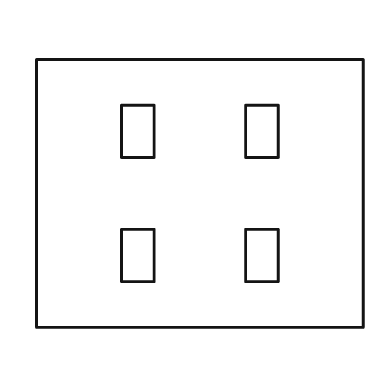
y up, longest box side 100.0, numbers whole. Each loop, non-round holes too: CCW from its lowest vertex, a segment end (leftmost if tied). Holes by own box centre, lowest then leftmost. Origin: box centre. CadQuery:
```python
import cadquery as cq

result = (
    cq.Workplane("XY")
    .moveTo(-50.0, -41.0)
    .lineTo(50.0, -41.0)
    .lineTo(50.0, 41.0)
    .lineTo(-50.0, 41.0)
    .close()
    .moveTo(-24.0, -27.0)
    .lineTo(-14.0, -27.0)
    .lineTo(-14.0, -11.0)
    .lineTo(-24.0, -11.0)
    .close()
    .moveTo(14.0, -27.0)
    .lineTo(24.0, -27.0)
    .lineTo(24.0, -11.0)
    .lineTo(14.0, -11.0)
    .close()
    .moveTo(-24.0, 11.0)
    .lineTo(-14.0, 11.0)
    .lineTo(-14.0, 27.0)
    .lineTo(-24.0, 27.0)
    .close()
    .moveTo(14.0, 11.0)
    .lineTo(24.0, 11.0)
    .lineTo(24.0, 27.0)
    .lineTo(14.0, 27.0)
    .close()
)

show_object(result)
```